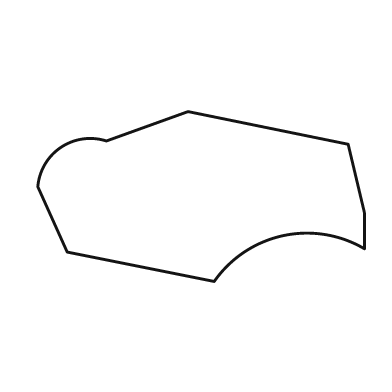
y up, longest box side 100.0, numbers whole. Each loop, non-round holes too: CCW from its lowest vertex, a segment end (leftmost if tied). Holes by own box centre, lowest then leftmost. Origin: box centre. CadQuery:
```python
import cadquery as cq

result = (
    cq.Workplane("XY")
    .moveTo(4.0, -26.0)
    .threePointArc((25.0, -12.0), (50.0, -16.0))
    .lineTo(50.0, -5.0)
    .lineTo(45.0, 16.0)
    .lineTo(-4.0, 26.0)
    .lineTo(-29.0, 17.0)
    .threePointArc((-43.0, 15.0), (-50.0, 3.0))
    .lineTo(-41.0, -17.0)
    .close()
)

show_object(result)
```